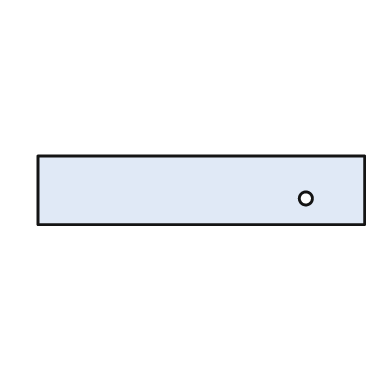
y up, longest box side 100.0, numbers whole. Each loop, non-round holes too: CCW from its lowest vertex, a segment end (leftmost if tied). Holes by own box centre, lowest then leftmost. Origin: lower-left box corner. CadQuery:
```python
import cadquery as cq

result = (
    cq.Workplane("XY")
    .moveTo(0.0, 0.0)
    .lineTo(100.0, 0.0)
    .lineTo(100.0, 21.0)
    .lineTo(0.0, 21.0)
    .close()
    .moveTo(82.0, 8.0)
    .circle(2.0)
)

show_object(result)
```